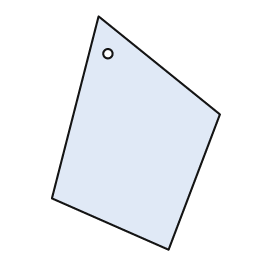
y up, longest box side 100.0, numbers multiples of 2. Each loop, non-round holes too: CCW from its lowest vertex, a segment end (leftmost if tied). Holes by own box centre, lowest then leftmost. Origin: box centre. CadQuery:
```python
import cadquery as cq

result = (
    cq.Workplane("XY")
    .moveTo(14.0, -50.0)
    .lineTo(36.0, 8.0)
    .lineTo(-16.0, 50.0)
    .lineTo(-36.0, -28.0)
    .close()
    .moveTo(-12.0, 34.0)
    .circle(2.0)
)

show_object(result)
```